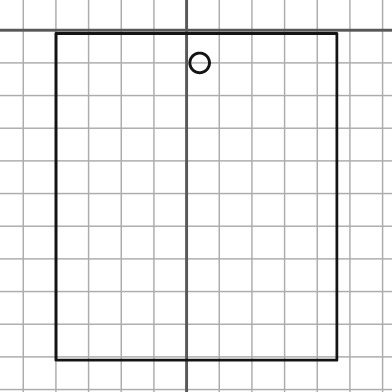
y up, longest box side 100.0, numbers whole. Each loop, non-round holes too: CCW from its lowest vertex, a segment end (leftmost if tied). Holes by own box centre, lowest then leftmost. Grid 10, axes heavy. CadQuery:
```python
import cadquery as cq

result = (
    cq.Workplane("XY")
    .moveTo(-40.0, -101.0)
    .lineTo(46.0, -101.0)
    .lineTo(46.0, -1.0)
    .lineTo(-40.0, -1.0)
    .close()
    .moveTo(4.0, -10.0)
    .circle(3.0)
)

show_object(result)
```